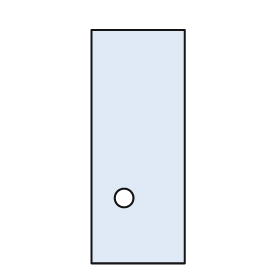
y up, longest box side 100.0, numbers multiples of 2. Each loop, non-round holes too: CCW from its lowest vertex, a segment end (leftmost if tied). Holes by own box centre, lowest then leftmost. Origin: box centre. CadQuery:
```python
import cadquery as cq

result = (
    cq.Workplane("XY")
    .moveTo(-20.0, -50.0)
    .lineTo(20.0, -50.0)
    .lineTo(20.0, 50.0)
    .lineTo(-20.0, 50.0)
    .close()
    .moveTo(-6.0, -22.0)
    .circle(4.0)
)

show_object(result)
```